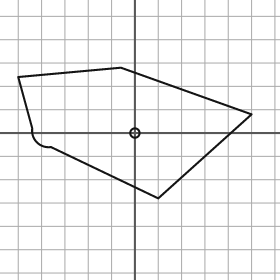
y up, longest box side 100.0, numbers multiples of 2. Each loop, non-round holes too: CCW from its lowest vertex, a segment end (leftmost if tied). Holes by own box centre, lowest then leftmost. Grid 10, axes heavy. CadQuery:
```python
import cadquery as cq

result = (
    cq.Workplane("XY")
    .moveTo(10.0, -28.0)
    .lineTo(50.0, 8.0)
    .lineTo(-6.0, 28.0)
    .lineTo(-50.0, 24.0)
    .lineTo(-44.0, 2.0)
    .threePointArc((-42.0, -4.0), (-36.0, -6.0))
    .close()
    .moveTo(0.0, 0.0)
    .circle(2.0)
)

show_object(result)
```